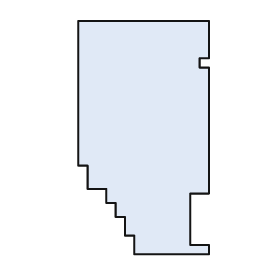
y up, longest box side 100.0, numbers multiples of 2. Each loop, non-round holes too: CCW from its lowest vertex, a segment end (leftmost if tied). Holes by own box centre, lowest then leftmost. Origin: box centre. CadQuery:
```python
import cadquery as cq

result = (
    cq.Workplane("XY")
    .moveTo(-4.0, -50.0)
    .lineTo(28.0, -50.0)
    .lineTo(28.0, -46.0)
    .lineTo(20.0, -46.0)
    .lineTo(20.0, -24.0)
    .lineTo(28.0, -24.0)
    .lineTo(28.0, 30.0)
    .lineTo(24.0, 30.0)
    .lineTo(24.0, 34.0)
    .lineTo(28.0, 34.0)
    .lineTo(28.0, 50.0)
    .lineTo(-28.0, 50.0)
    .lineTo(-28.0, -12.0)
    .lineTo(-24.0, -12.0)
    .lineTo(-24.0, -22.0)
    .lineTo(-16.0, -22.0)
    .lineTo(-16.0, -28.0)
    .lineTo(-12.0, -28.0)
    .lineTo(-12.0, -34.0)
    .lineTo(-8.0, -34.0)
    .lineTo(-8.0, -42.0)
    .lineTo(-4.0, -42.0)
    .close()
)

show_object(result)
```